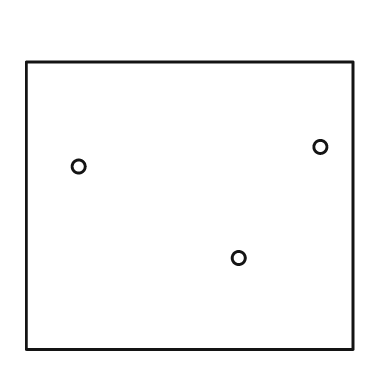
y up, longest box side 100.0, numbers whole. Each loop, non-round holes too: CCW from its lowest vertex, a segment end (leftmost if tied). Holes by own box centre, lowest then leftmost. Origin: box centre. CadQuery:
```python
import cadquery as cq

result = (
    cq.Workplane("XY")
    .moveTo(-50.0, -44.0)
    .lineTo(50.0, -44.0)
    .lineTo(50.0, 44.0)
    .lineTo(-50.0, 44.0)
    .close()
    .moveTo(15.0, -16.0)
    .circle(2.0)
    .moveTo(-34.0, 12.0)
    .circle(2.0)
    .moveTo(40.0, 18.0)
    .circle(2.0)
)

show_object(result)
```